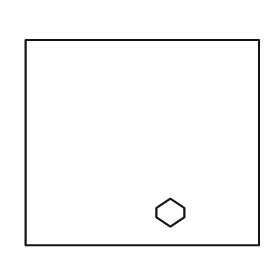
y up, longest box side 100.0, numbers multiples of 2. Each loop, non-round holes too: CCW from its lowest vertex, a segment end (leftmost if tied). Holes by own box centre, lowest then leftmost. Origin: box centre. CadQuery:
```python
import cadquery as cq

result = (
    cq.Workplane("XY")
    .moveTo(-50.0, -44.0)
    .lineTo(50.0, -44.0)
    .lineTo(50.0, 44.0)
    .lineTo(-50.0, 44.0)
    .close()
    .moveTo(12.0, -36.0)
    .lineTo(18.0, -32.0)
    .lineTo(18.0, -28.0)
    .lineTo(12.0, -24.0)
    .lineTo(6.0, -28.0)
    .lineTo(6.0, -32.0)
    .close()
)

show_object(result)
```